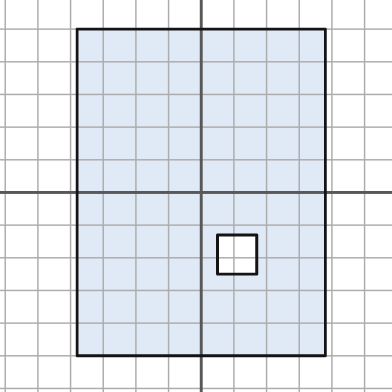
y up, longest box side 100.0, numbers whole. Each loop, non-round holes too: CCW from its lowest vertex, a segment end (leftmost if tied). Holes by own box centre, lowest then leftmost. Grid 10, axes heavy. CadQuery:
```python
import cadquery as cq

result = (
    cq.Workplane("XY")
    .moveTo(-38.0, -50.0)
    .lineTo(38.0, -50.0)
    .lineTo(38.0, 50.0)
    .lineTo(-38.0, 50.0)
    .close()
    .moveTo(5.0, -25.0)
    .lineTo(17.0, -25.0)
    .lineTo(17.0, -13.0)
    .lineTo(5.0, -13.0)
    .close()
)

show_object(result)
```